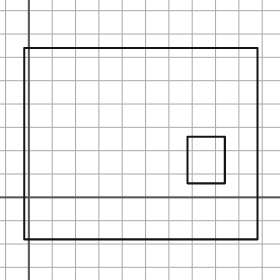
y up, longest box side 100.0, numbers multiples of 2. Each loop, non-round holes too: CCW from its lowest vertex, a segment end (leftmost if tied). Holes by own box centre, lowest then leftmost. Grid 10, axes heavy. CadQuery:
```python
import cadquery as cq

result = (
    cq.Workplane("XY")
    .moveTo(-2.0, -18.0)
    .lineTo(98.0, -18.0)
    .lineTo(98.0, 64.0)
    .lineTo(-2.0, 64.0)
    .close()
    .moveTo(68.0, 6.0)
    .lineTo(84.0, 6.0)
    .lineTo(84.0, 26.0)
    .lineTo(68.0, 26.0)
    .close()
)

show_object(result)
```